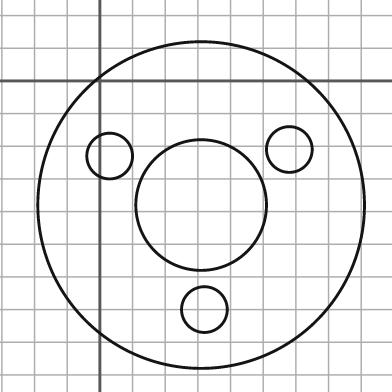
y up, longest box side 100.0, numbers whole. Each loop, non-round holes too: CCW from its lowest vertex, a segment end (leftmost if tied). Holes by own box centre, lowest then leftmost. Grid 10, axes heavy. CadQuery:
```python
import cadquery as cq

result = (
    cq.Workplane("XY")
    .moveTo(31.0, -38.0)
    .circle(50.0)
    .moveTo(32.0, -70.0)
    .circle(7.0)
    .moveTo(31.0, -38.0)
    .circle(20.0)
    .moveTo(3.0, -23.0)
    .circle(7.0)
    .moveTo(58.0, -21.0)
    .circle(7.0)
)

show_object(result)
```